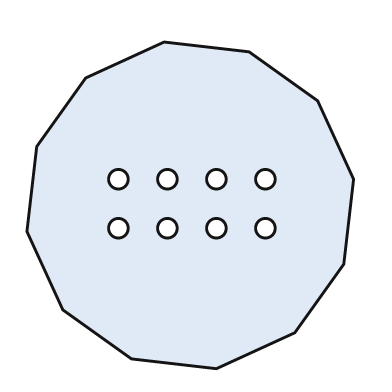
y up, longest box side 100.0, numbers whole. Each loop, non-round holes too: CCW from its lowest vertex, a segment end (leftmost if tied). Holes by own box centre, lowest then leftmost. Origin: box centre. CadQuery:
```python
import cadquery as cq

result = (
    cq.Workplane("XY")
    .moveTo(8.0, -50.0)
    .lineTo(32.0, -39.0)
    .lineTo(47.0, -18.0)
    .lineTo(50.0, 8.0)
    .lineTo(39.0, 32.0)
    .lineTo(18.0, 47.0)
    .lineTo(-8.0, 50.0)
    .lineTo(-32.0, 39.0)
    .lineTo(-47.0, 18.0)
    .lineTo(-50.0, -8.0)
    .lineTo(-39.0, -32.0)
    .lineTo(-18.0, -47.0)
    .close()
    .moveTo(-22.0, -7.0)
    .circle(3.0)
    .moveTo(-7.0, -7.0)
    .circle(3.0)
    .moveTo(8.0, -7.0)
    .circle(3.0)
    .moveTo(23.0, -7.0)
    .circle(3.0)
    .moveTo(-22.0, 8.0)
    .circle(3.0)
    .moveTo(-7.0, 8.0)
    .circle(3.0)
    .moveTo(8.0, 8.0)
    .circle(3.0)
    .moveTo(23.0, 8.0)
    .circle(3.0)
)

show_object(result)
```